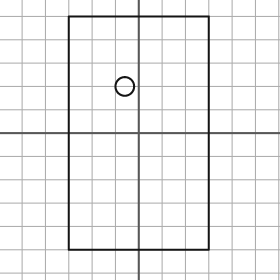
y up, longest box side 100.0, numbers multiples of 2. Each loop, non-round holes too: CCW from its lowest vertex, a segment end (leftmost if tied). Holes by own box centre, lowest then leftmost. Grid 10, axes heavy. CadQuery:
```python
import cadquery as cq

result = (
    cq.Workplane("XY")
    .moveTo(-30.0, -50.0)
    .lineTo(30.0, -50.0)
    .lineTo(30.0, 50.0)
    .lineTo(-30.0, 50.0)
    .close()
    .moveTo(-6.0, 20.0)
    .circle(4.0)
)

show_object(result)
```